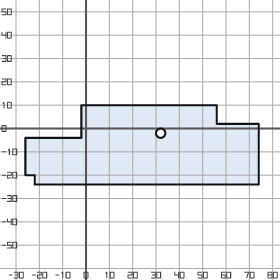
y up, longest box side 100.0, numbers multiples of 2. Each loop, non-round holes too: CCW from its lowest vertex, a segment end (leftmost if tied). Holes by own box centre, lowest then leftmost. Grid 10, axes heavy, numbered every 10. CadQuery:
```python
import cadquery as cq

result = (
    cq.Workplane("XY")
    .moveTo(-22.0, -24.0)
    .lineTo(74.0, -24.0)
    .lineTo(74.0, 2.0)
    .lineTo(56.0, 2.0)
    .lineTo(56.0, 10.0)
    .lineTo(-2.0, 10.0)
    .lineTo(-2.0, -4.0)
    .lineTo(-26.0, -4.0)
    .lineTo(-26.0, -20.0)
    .lineTo(-22.0, -20.0)
    .close()
    .moveTo(32.0, -2.0)
    .circle(2.0)
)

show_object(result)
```